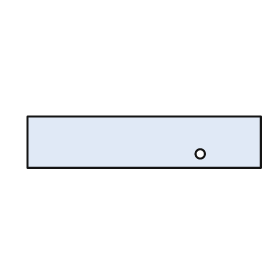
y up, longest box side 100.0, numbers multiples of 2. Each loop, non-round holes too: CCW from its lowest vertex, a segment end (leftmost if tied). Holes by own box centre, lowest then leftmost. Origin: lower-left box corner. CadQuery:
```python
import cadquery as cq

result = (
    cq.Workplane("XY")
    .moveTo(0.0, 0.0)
    .lineTo(100.0, 0.0)
    .lineTo(100.0, 22.0)
    .lineTo(0.0, 22.0)
    .close()
    .moveTo(74.0, 6.0)
    .circle(2.0)
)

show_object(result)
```